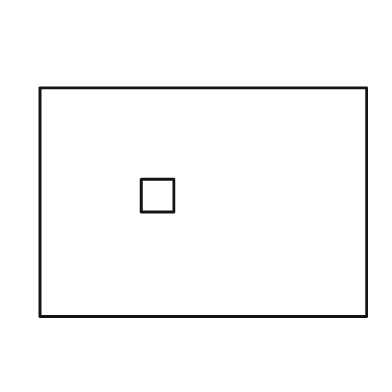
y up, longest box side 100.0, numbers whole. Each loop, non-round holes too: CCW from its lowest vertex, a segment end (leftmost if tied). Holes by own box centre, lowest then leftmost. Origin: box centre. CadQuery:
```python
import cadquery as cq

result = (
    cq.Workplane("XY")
    .moveTo(-50.0, -35.0)
    .lineTo(50.0, -35.0)
    .lineTo(50.0, 35.0)
    .lineTo(-50.0, 35.0)
    .close()
    .moveTo(-19.0, -3.0)
    .lineTo(-9.0, -3.0)
    .lineTo(-9.0, 7.0)
    .lineTo(-19.0, 7.0)
    .close()
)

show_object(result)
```